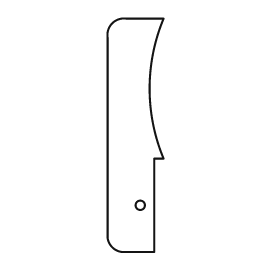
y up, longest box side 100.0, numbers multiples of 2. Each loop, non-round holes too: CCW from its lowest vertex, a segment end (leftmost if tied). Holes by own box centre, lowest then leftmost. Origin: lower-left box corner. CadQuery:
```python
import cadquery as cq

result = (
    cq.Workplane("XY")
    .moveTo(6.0, 0.0)
    .lineTo(20.0, 0.0)
    .lineTo(20.0, 40.0)
    .lineTo(24.0, 40.0)
    .threePointArc((18.0, 70.0), (24.0, 100.0))
    .lineTo(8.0, 100.0)
    .threePointArc((2.0, 98.0), (0.0, 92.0))
    .lineTo(0.0, 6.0)
    .threePointArc((2.0, 2.0), (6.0, 0.0))
    .close()
    .moveTo(14.0, 20.0)
    .circle(2.0)
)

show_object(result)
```